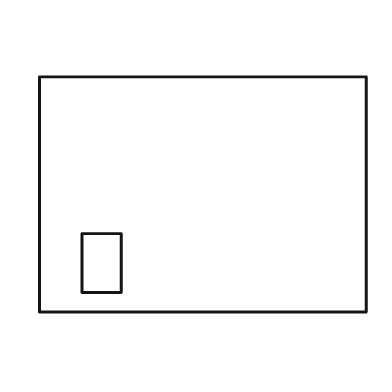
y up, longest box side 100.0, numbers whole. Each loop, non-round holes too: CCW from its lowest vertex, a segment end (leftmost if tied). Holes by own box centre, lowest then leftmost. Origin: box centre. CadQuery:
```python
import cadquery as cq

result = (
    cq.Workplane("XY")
    .moveTo(-50.0, -36.0)
    .lineTo(50.0, -36.0)
    .lineTo(50.0, 36.0)
    .lineTo(-50.0, 36.0)
    .close()
    .moveTo(-37.0, -30.0)
    .lineTo(-25.0, -30.0)
    .lineTo(-25.0, -12.0)
    .lineTo(-37.0, -12.0)
    .close()
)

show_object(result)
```